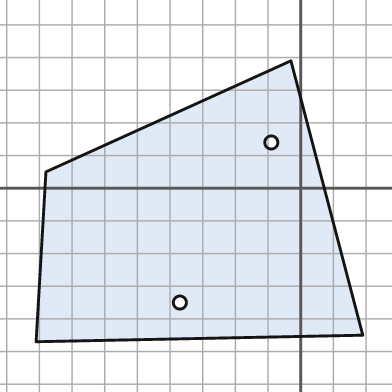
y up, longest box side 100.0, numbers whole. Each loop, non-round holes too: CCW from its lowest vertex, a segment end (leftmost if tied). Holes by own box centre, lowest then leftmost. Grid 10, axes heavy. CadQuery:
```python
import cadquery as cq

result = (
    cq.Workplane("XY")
    .moveTo(-81.0, -47.0)
    .lineTo(19.0, -45.0)
    .lineTo(-3.0, 39.0)
    .lineTo(-78.0, 5.0)
    .close()
    .moveTo(-37.0, -35.0)
    .circle(2.0)
    .moveTo(-9.0, 14.0)
    .circle(2.0)
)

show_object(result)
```